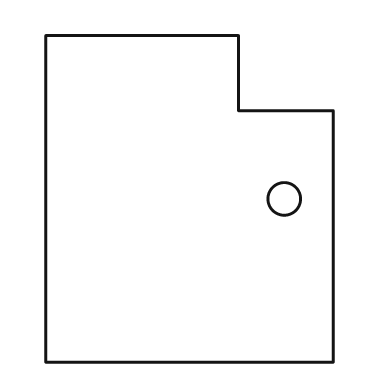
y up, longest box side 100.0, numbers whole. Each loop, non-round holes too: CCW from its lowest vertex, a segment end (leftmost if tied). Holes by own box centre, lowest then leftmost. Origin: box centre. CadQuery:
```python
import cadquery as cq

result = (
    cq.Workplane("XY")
    .moveTo(-44.0, -50.0)
    .lineTo(44.0, -50.0)
    .lineTo(44.0, 27.0)
    .lineTo(15.0, 27.0)
    .lineTo(15.0, 50.0)
    .lineTo(-44.0, 50.0)
    .close()
    .moveTo(29.0, 0.0)
    .circle(5.0)
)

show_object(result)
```